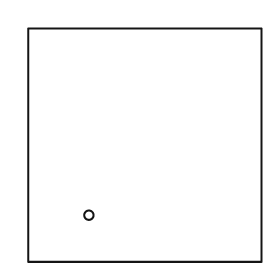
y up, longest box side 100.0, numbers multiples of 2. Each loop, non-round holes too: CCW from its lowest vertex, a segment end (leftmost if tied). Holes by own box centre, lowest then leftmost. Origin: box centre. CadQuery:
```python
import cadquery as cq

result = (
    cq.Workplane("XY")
    .moveTo(-50.0, -50.0)
    .lineTo(50.0, -50.0)
    .lineTo(50.0, 50.0)
    .lineTo(-50.0, 50.0)
    .close()
    .moveTo(-24.0, -30.0)
    .circle(2.0)
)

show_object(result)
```